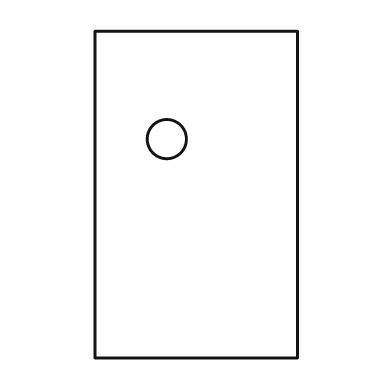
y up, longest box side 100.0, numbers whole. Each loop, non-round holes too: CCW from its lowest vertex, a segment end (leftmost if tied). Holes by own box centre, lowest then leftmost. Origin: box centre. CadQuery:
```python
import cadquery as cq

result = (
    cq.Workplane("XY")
    .moveTo(-31.0, -50.0)
    .lineTo(31.0, -50.0)
    .lineTo(31.0, 50.0)
    .lineTo(-31.0, 50.0)
    .close()
    .moveTo(-9.0, 17.0)
    .circle(6.0)
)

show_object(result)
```